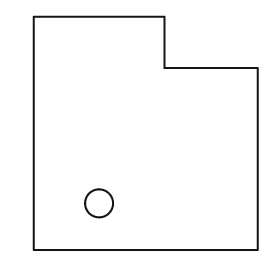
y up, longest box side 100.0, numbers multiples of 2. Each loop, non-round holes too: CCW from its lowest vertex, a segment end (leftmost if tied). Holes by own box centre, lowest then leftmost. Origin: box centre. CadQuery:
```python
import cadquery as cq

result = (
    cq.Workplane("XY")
    .moveTo(-48.0, -50.0)
    .lineTo(48.0, -50.0)
    .lineTo(48.0, 28.0)
    .lineTo(8.0, 28.0)
    .lineTo(8.0, 50.0)
    .lineTo(-48.0, 50.0)
    .close()
    .moveTo(-20.0, -30.0)
    .circle(6.0)
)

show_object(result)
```